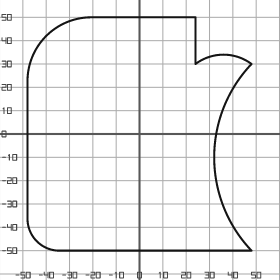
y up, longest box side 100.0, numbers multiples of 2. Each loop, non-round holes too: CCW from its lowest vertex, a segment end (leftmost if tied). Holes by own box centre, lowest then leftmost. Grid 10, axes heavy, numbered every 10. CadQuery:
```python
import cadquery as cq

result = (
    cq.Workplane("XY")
    .moveTo(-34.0, -50.0)
    .lineTo(48.0, -50.0)
    .threePointArc((32.0, -10.0), (48.0, 30.0))
    .threePointArc((36.0, 34.0), (24.0, 30.0))
    .lineTo(24.0, 50.0)
    .lineTo(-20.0, 50.0)
    .threePointArc((-40.0, 42.0), (-48.0, 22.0))
    .lineTo(-48.0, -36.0)
    .threePointArc((-44.0, -46.0), (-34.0, -50.0))
    .close()
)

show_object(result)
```